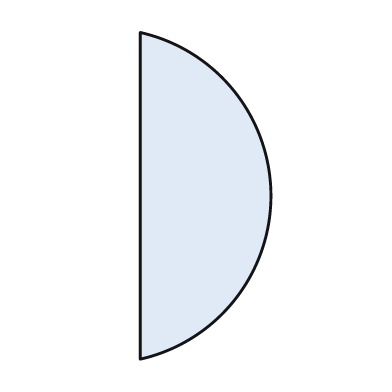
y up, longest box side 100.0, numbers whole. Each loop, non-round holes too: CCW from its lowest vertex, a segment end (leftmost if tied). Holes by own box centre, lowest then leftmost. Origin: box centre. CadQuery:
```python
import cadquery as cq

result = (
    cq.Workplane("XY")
    .moveTo(-20.0, -50.0)
    .threePointArc((20.0, 0.0), (-20.0, 50.0))
    .close()
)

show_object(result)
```